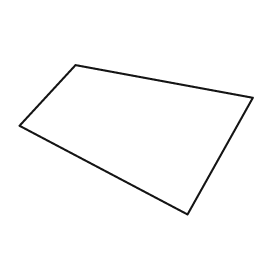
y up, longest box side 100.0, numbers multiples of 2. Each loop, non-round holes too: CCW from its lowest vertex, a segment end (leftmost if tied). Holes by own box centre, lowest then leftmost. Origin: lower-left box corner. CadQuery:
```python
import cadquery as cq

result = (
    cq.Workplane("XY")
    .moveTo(72.0, 0.0)
    .lineTo(100.0, 50.0)
    .lineTo(24.0, 64.0)
    .lineTo(0.0, 38.0)
    .close()
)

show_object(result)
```